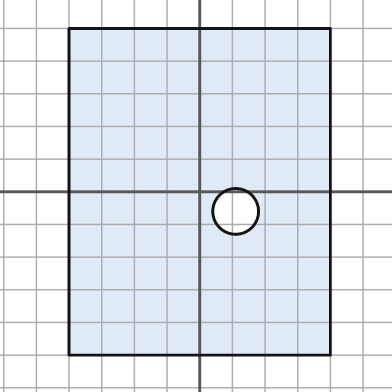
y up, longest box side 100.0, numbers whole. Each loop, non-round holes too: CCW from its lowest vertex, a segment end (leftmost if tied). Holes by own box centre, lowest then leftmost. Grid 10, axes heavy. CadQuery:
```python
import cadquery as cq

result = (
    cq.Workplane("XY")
    .moveTo(-40.0, -50.0)
    .lineTo(40.0, -50.0)
    .lineTo(40.0, 50.0)
    .lineTo(-40.0, 50.0)
    .close()
    .moveTo(11.0, -6.0)
    .circle(7.0)
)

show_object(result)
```